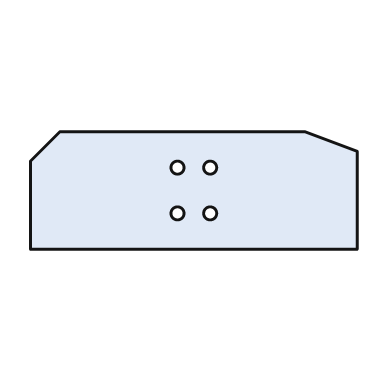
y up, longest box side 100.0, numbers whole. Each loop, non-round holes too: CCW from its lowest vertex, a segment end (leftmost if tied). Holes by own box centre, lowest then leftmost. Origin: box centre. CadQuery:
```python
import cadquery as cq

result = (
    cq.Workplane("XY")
    .moveTo(-50.0, -18.0)
    .lineTo(50.0, -18.0)
    .lineTo(50.0, 12.0)
    .lineTo(34.0, 18.0)
    .lineTo(-41.0, 18.0)
    .lineTo(-50.0, 9.0)
    .close()
    .moveTo(-5.0, -7.0)
    .circle(2.0)
    .moveTo(5.0, -7.0)
    .circle(2.0)
    .moveTo(-5.0, 7.0)
    .circle(2.0)
    .moveTo(5.0, 7.0)
    .circle(2.0)
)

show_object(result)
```